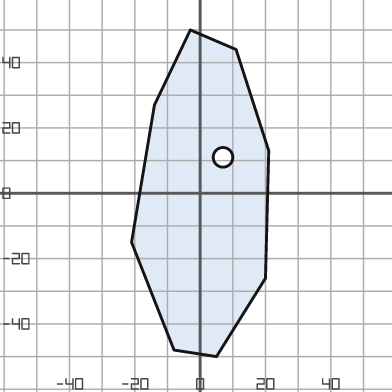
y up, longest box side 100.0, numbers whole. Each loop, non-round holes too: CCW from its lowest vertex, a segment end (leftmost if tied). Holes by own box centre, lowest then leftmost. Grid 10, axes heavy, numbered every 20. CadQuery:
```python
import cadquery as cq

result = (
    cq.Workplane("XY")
    .moveTo(5.0, -50.0)
    .lineTo(20.0, -26.0)
    .lineTo(21.0, 13.0)
    .lineTo(11.0, 44.0)
    .lineTo(-3.0, 50.0)
    .lineTo(-14.0, 27.0)
    .lineTo(-21.0, -15.0)
    .lineTo(-8.0, -48.0)
    .close()
    .moveTo(7.0, 11.0)
    .circle(3.0)
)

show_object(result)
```